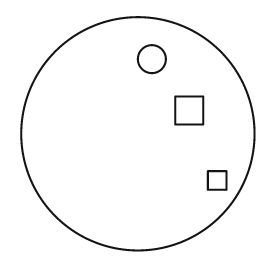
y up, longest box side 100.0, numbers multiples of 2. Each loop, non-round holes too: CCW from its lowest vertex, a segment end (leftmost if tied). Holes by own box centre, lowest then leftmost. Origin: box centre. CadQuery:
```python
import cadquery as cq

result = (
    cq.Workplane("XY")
    .moveTo(0.0, 0.0)
    .circle(50.0)
    .moveTo(30.0, -24.0)
    .lineTo(38.0, -24.0)
    .lineTo(38.0, -16.0)
    .lineTo(30.0, -16.0)
    .close()
    .moveTo(16.0, 4.0)
    .lineTo(28.0, 4.0)
    .lineTo(28.0, 16.0)
    .lineTo(16.0, 16.0)
    .close()
    .moveTo(6.0, 32.0)
    .circle(6.0)
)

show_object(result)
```